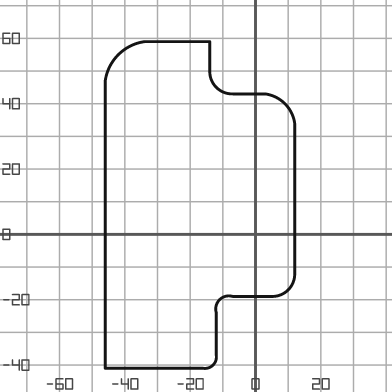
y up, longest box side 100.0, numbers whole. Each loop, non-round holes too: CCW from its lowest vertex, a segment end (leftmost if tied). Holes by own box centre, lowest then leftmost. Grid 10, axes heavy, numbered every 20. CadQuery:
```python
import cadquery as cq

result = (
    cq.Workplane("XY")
    .moveTo(-46.0, -41.0)
    .lineTo(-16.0, -41.0)
    .threePointArc((-13.0, -40.0), (-12.0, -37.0))
    .lineTo(-12.0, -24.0)
    .threePointArc((-11.0, -20.0), (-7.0, -19.0))
    .lineTo(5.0, -19.0)
    .threePointArc((10.0, -17.0), (12.0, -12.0))
    .lineTo(12.0, 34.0)
    .threePointArc((9.0, 40.0), (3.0, 43.0))
    .lineTo(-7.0, 43.0)
    .threePointArc((-12.0, 45.0), (-14.0, 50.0))
    .lineTo(-14.0, 59.0)
    .lineTo(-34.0, 59.0)
    .threePointArc((-42.0, 55.0), (-46.0, 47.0))
    .close()
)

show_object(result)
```